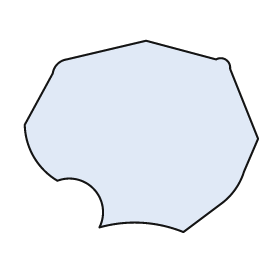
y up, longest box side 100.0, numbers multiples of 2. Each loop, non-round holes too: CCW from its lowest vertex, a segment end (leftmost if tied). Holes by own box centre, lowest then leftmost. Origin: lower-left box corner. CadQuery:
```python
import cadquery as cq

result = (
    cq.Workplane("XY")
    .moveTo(68.0, 0.0)
    .lineTo(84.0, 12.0)
    .threePointArc((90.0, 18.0), (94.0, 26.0))
    .lineTo(100.0, 40.0)
    .lineTo(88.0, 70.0)
    .threePointArc((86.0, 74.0), (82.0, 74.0))
    .lineTo(52.0, 82.0)
    .lineTo(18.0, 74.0)
    .threePointArc((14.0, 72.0), (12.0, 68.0))
    .lineTo(0.0, 46.0)
    .threePointArc((4.0, 32.0), (14.0, 22.0))
    .threePointArc((30.0, 18.0), (32.0, 2.0))
    .threePointArc((50.0, 4.0), (68.0, 0.0))
    .close()
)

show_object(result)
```